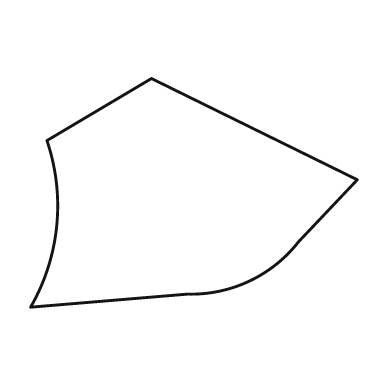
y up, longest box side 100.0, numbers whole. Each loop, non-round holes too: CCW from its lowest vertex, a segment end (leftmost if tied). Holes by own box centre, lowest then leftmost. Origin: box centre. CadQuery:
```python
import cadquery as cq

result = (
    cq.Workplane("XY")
    .moveTo(-50.0, -35.0)
    .lineTo(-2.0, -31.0)
    .threePointArc((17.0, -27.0), (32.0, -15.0))
    .lineTo(50.0, 4.0)
    .lineTo(-13.0, 35.0)
    .lineTo(-45.0, 16.0)
    .threePointArc((-42.0, -10.0), (-50.0, -35.0))
    .close()
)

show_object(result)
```